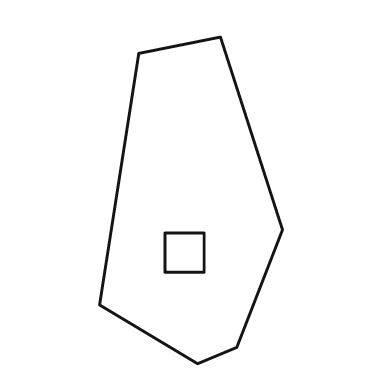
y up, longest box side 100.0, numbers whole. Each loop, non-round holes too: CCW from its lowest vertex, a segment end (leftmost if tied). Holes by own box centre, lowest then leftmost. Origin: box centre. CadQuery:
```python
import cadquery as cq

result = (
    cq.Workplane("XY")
    .moveTo(2.0, -50.0)
    .lineTo(14.0, -45.0)
    .lineTo(28.0, -9.0)
    .lineTo(9.0, 50.0)
    .lineTo(-16.0, 45.0)
    .lineTo(-28.0, -32.0)
    .close()
    .moveTo(-8.0, -22.0)
    .lineTo(4.0, -22.0)
    .lineTo(4.0, -10.0)
    .lineTo(-8.0, -10.0)
    .close()
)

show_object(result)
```